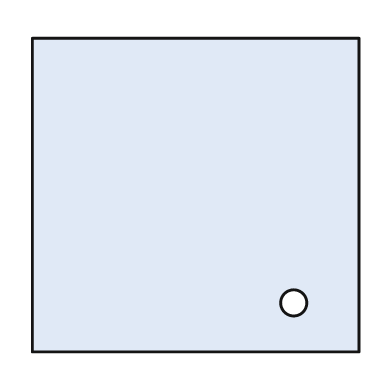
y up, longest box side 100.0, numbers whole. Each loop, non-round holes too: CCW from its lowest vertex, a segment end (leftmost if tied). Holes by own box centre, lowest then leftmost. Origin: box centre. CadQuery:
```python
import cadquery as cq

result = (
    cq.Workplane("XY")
    .moveTo(-50.0, -48.0)
    .lineTo(50.0, -48.0)
    .lineTo(50.0, 48.0)
    .lineTo(-50.0, 48.0)
    .close()
    .moveTo(30.0, -33.0)
    .circle(4.0)
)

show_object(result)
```